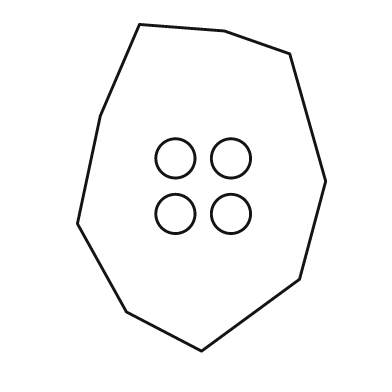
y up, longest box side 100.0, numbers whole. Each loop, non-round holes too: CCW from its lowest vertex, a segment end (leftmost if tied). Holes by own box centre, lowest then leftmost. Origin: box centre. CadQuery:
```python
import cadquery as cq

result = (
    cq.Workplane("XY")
    .moveTo(0.0, -50.0)
    .lineTo(30.0, -28.0)
    .lineTo(38.0, 2.0)
    .lineTo(27.0, 41.0)
    .lineTo(7.0, 48.0)
    .lineTo(-19.0, 50.0)
    .lineTo(-31.0, 22.0)
    .lineTo(-38.0, -11.0)
    .lineTo(-23.0, -38.0)
    .close()
    .moveTo(-8.0, -8.0)
    .circle(6.0)
    .moveTo(9.0, -8.0)
    .circle(6.0)
    .moveTo(-8.0, 9.0)
    .circle(6.0)
    .moveTo(9.0, 9.0)
    .circle(6.0)
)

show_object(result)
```